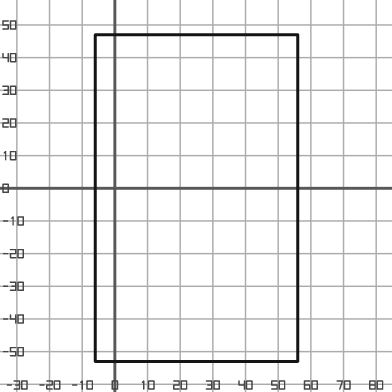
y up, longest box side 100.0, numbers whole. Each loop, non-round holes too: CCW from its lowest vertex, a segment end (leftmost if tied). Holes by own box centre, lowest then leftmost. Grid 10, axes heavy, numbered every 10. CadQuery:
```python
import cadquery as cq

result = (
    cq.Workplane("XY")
    .moveTo(-6.0, -53.0)
    .lineTo(56.0, -53.0)
    .lineTo(56.0, 47.0)
    .lineTo(-6.0, 47.0)
    .close()
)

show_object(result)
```